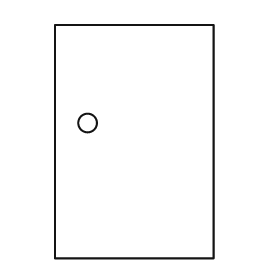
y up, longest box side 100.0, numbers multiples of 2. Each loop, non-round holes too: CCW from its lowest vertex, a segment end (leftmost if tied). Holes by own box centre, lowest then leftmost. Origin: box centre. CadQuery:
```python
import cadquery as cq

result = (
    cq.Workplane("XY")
    .moveTo(-34.0, -50.0)
    .lineTo(34.0, -50.0)
    .lineTo(34.0, 50.0)
    .lineTo(-34.0, 50.0)
    .close()
    .moveTo(-20.0, 8.0)
    .circle(4.0)
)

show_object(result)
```